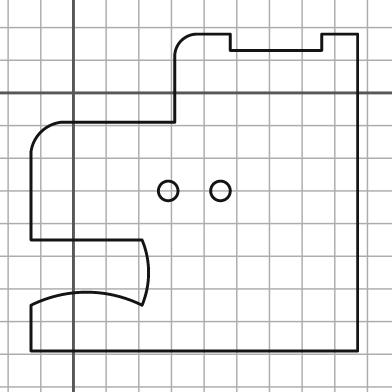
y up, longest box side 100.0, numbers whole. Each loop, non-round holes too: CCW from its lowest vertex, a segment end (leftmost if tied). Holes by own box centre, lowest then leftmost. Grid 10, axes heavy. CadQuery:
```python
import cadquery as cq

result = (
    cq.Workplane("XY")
    .moveTo(-13.0, -79.0)
    .lineTo(87.0, -79.0)
    .lineTo(87.0, 18.0)
    .lineTo(76.0, 18.0)
    .lineTo(76.0, 13.0)
    .lineTo(48.0, 13.0)
    .lineTo(48.0, 18.0)
    .lineTo(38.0, 18.0)
    .threePointArc((33.0, 16.0), (31.0, 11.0))
    .lineTo(31.0, -9.0)
    .lineTo(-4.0, -9.0)
    .threePointArc((-10.0, -12.0), (-13.0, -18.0))
    .lineTo(-13.0, -45.0)
    .lineTo(21.0, -45.0)
    .threePointArc((23.0, -55.0), (21.0, -65.0))
    .threePointArc((4.0, -61.0), (-13.0, -65.0))
    .close()
    .moveTo(29.0, -30.0)
    .circle(3.0)
    .moveTo(45.0, -30.0)
    .circle(3.0)
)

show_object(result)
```